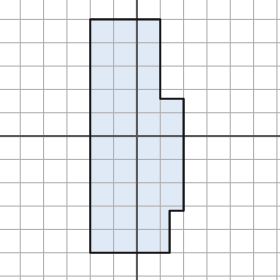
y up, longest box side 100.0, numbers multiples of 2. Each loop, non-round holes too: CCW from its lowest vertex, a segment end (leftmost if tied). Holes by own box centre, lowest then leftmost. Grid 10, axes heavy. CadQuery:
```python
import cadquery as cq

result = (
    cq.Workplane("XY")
    .moveTo(-20.0, -50.0)
    .lineTo(14.0, -50.0)
    .lineTo(14.0, -32.0)
    .lineTo(20.0, -32.0)
    .lineTo(20.0, 16.0)
    .lineTo(10.0, 16.0)
    .lineTo(10.0, 50.0)
    .lineTo(-20.0, 50.0)
    .close()
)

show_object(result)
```